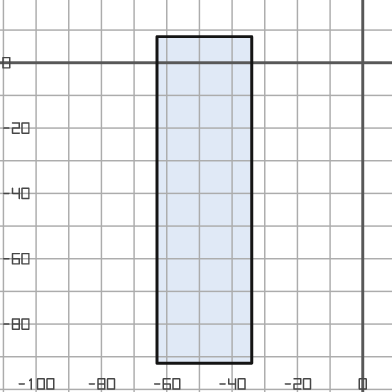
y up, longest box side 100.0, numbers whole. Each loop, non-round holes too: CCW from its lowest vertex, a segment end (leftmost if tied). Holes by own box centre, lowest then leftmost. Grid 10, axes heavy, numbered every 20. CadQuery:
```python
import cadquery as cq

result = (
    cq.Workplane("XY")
    .moveTo(-63.0, -92.0)
    .lineTo(-34.0, -92.0)
    .lineTo(-34.0, 8.0)
    .lineTo(-63.0, 8.0)
    .close()
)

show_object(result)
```